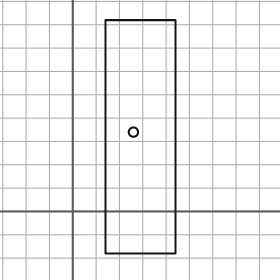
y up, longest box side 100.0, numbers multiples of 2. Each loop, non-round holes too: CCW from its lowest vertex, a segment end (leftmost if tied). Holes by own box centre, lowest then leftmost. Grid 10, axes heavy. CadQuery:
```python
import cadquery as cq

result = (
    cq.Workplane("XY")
    .moveTo(14.0, -18.0)
    .lineTo(44.0, -18.0)
    .lineTo(44.0, 82.0)
    .lineTo(14.0, 82.0)
    .close()
    .moveTo(26.0, 34.0)
    .circle(2.0)
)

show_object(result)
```